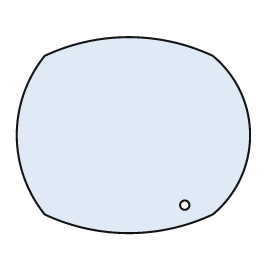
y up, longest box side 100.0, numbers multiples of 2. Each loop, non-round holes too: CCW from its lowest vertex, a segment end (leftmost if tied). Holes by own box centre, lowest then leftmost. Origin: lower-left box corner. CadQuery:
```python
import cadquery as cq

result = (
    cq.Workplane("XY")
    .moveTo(12.0, 8.0)
    .threePointArc((48.0, 0.0), (84.0, 8.0))
    .threePointArc((100.0, 42.0), (84.0, 76.0))
    .threePointArc((48.0, 84.0), (12.0, 76.0))
    .threePointArc((0.0, 42.0), (12.0, 8.0))
    .close()
    .moveTo(72.0, 12.0)
    .circle(2.0)
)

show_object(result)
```